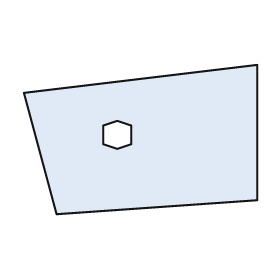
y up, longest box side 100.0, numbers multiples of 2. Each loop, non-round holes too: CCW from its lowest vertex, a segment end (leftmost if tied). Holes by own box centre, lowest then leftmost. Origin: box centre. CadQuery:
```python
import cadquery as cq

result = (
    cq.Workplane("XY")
    .moveTo(-36.0, -32.0)
    .lineTo(50.0, -26.0)
    .lineTo(50.0, 32.0)
    .lineTo(-50.0, 20.0)
    .close()
    .moveTo(-10.0, -4.0)
    .lineTo(-4.0, -2.0)
    .lineTo(-4.0, 6.0)
    .lineTo(-10.0, 8.0)
    .lineTo(-16.0, 6.0)
    .lineTo(-16.0, -2.0)
    .close()
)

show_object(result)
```